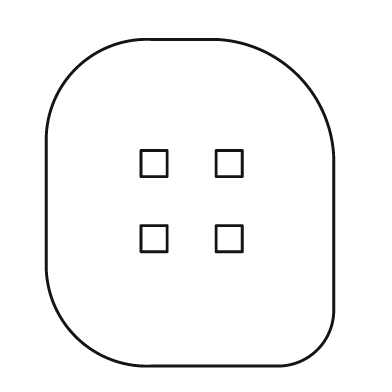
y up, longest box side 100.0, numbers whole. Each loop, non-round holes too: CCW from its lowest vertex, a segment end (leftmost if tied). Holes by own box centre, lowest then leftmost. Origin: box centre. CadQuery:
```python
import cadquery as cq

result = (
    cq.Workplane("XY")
    .moveTo(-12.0, -50.0)
    .lineTo(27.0, -50.0)
    .threePointArc((39.0, -45.0), (44.0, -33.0))
    .lineTo(44.0, 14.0)
    .threePointArc((33.0, 39.0), (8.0, 50.0))
    .lineTo(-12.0, 50.0)
    .threePointArc((-35.0, 41.0), (-44.0, 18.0))
    .lineTo(-44.0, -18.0)
    .threePointArc((-35.0, -41.0), (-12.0, -50.0))
    .close()
    .moveTo(-15.0, -15.0)
    .lineTo(-7.0, -15.0)
    .lineTo(-7.0, -7.0)
    .lineTo(-15.0, -7.0)
    .close()
    .moveTo(8.0, -15.0)
    .lineTo(16.0, -15.0)
    .lineTo(16.0, -7.0)
    .lineTo(8.0, -7.0)
    .close()
    .moveTo(-15.0, 8.0)
    .lineTo(-7.0, 8.0)
    .lineTo(-7.0, 16.0)
    .lineTo(-15.0, 16.0)
    .close()
    .moveTo(8.0, 8.0)
    .lineTo(16.0, 8.0)
    .lineTo(16.0, 16.0)
    .lineTo(8.0, 16.0)
    .close()
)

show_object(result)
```